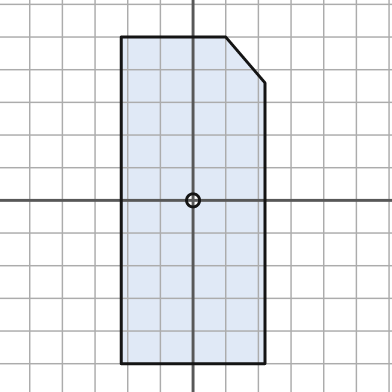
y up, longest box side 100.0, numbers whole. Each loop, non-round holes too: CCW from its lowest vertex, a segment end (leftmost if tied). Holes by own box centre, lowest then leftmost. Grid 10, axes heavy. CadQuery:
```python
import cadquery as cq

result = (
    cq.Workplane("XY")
    .moveTo(-22.0, -50.0)
    .lineTo(22.0, -50.0)
    .lineTo(22.0, 36.0)
    .lineTo(10.0, 50.0)
    .lineTo(-22.0, 50.0)
    .close()
    .moveTo(0.0, 0.0)
    .circle(2.0)
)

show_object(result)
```